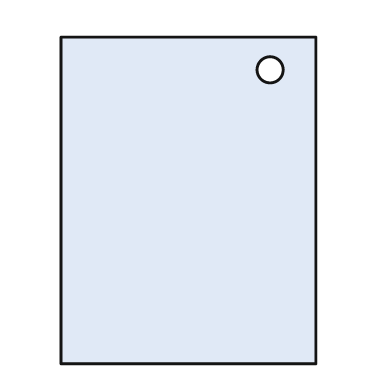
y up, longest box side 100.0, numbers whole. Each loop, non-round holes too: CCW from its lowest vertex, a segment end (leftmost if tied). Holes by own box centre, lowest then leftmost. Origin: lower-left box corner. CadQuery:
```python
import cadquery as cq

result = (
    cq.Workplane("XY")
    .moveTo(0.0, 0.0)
    .lineTo(78.0, 0.0)
    .lineTo(78.0, 100.0)
    .lineTo(0.0, 100.0)
    .close()
    .moveTo(64.0, 90.0)
    .circle(4.0)
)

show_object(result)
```